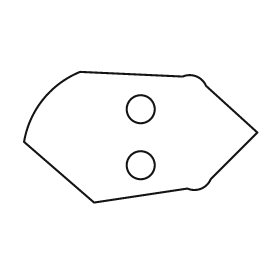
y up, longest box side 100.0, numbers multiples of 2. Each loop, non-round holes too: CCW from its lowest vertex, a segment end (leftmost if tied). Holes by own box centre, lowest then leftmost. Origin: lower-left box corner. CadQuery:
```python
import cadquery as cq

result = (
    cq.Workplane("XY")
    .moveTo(30.0, 0.0)
    .lineTo(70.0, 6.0)
    .threePointArc((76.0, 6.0), (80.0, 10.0))
    .lineTo(100.0, 30.0)
    .lineTo(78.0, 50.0)
    .threePointArc((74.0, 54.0), (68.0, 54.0))
    .lineTo(24.0, 56.0)
    .threePointArc((8.0, 44.0), (0.0, 26.0))
    .close()
    .moveTo(50.0, 16.0)
    .circle(6.0)
    .moveTo(50.0, 40.0)
    .circle(6.0)
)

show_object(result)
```